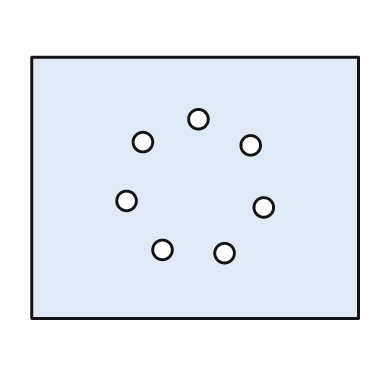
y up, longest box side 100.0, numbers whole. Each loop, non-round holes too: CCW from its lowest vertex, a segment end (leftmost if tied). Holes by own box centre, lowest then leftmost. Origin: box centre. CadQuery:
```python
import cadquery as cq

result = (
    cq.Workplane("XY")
    .moveTo(-50.0, -40.0)
    .lineTo(50.0, -40.0)
    .lineTo(50.0, 40.0)
    .lineTo(-50.0, 40.0)
    .close()
    .moveTo(9.0, -20.0)
    .circle(3.0)
    .moveTo(-10.0, -19.0)
    .circle(3.0)
    .moveTo(21.0, -6.0)
    .circle(3.0)
    .moveTo(-21.0, -4.0)
    .circle(3.0)
    .moveTo(17.0, 13.0)
    .circle(3.0)
    .moveTo(-16.0, 14.0)
    .circle(3.0)
    .moveTo(1.0, 21.0)
    .circle(3.0)
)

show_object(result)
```